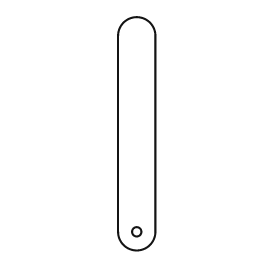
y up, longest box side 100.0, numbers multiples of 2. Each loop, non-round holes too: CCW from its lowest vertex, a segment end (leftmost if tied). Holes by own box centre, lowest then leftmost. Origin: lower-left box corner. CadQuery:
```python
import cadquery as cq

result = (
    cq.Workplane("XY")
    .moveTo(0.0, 8.0)
    .threePointArc((8.0, 0.0), (16.0, 8.0))
    .lineTo(16.0, 92.0)
    .threePointArc((8.0, 100.0), (0.0, 92.0))
    .close()
    .moveTo(8.0, 8.0)
    .circle(2.0)
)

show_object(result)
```